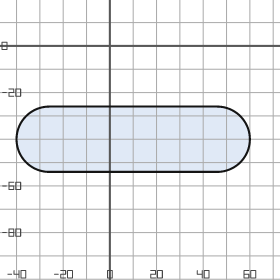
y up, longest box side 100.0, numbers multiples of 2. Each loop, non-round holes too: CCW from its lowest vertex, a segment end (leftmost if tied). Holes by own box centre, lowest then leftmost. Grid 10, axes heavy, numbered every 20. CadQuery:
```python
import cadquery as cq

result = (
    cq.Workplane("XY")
    .moveTo(-26.0, -54.0)
    .lineTo(46.0, -54.0)
    .threePointArc((60.0, -40.0), (46.0, -26.0))
    .lineTo(-26.0, -26.0)
    .threePointArc((-40.0, -40.0), (-26.0, -54.0))
    .close()
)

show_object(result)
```